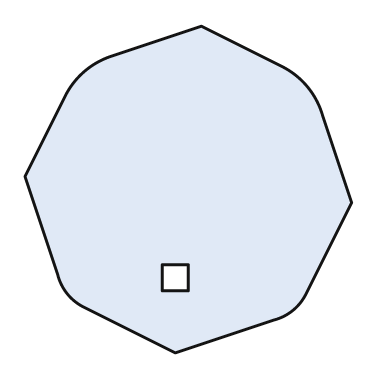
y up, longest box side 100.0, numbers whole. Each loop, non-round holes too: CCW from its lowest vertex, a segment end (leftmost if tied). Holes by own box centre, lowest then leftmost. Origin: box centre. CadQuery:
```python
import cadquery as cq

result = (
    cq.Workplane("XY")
    .moveTo(-4.0, -50.0)
    .lineTo(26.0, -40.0)
    .threePointArc((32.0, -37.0), (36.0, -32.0))
    .lineTo(50.0, -4.0)
    .lineTo(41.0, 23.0)
    .threePointArc((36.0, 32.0), (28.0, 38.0))
    .lineTo(4.0, 50.0)
    .lineTo(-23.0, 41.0)
    .threePointArc((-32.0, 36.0), (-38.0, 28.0))
    .lineTo(-50.0, 4.0)
    .lineTo(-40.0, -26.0)
    .threePointArc((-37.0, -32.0), (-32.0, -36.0))
    .close()
    .moveTo(-8.0, -31.0)
    .lineTo(0.0, -31.0)
    .lineTo(0.0, -23.0)
    .lineTo(-8.0, -23.0)
    .close()
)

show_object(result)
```